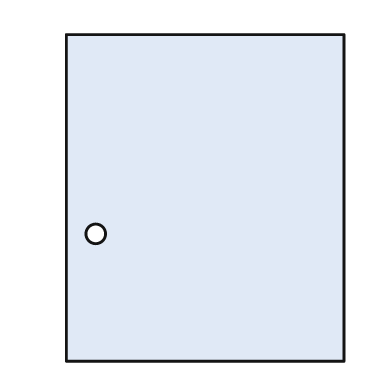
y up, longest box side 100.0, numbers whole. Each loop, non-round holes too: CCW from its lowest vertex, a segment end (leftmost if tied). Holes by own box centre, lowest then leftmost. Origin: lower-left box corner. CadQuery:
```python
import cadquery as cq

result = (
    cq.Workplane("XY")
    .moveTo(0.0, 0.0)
    .lineTo(85.0, 0.0)
    .lineTo(85.0, 100.0)
    .lineTo(0.0, 100.0)
    .close()
    .moveTo(9.0, 39.0)
    .circle(3.0)
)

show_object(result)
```